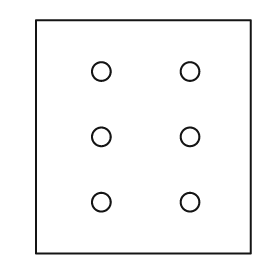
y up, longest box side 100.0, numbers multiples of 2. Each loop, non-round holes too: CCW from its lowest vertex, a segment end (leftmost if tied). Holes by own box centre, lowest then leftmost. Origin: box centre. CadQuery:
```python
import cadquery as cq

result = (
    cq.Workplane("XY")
    .moveTo(-46.0, -50.0)
    .lineTo(46.0, -50.0)
    .lineTo(46.0, 50.0)
    .lineTo(-46.0, 50.0)
    .close()
    .moveTo(-18.0, -28.0)
    .circle(4.0)
    .moveTo(20.0, -28.0)
    .circle(4.0)
    .moveTo(-18.0, 0.0)
    .circle(4.0)
    .moveTo(20.0, 0.0)
    .circle(4.0)
    .moveTo(-18.0, 28.0)
    .circle(4.0)
    .moveTo(20.0, 28.0)
    .circle(4.0)
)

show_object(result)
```